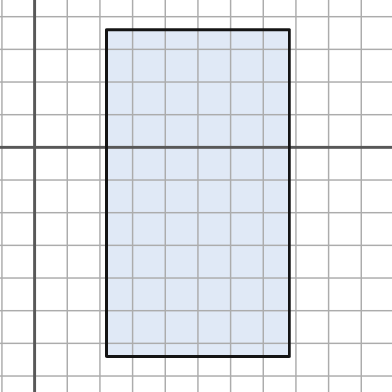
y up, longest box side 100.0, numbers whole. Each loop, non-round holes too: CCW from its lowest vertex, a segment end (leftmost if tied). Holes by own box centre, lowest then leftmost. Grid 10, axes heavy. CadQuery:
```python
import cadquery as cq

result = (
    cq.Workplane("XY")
    .moveTo(22.0, -64.0)
    .lineTo(78.0, -64.0)
    .lineTo(78.0, 36.0)
    .lineTo(22.0, 36.0)
    .close()
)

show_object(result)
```